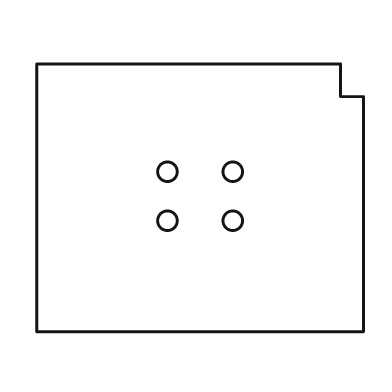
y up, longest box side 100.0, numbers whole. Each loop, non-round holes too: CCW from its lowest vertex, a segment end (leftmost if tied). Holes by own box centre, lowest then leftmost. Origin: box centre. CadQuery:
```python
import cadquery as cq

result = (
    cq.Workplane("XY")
    .moveTo(-50.0, -41.0)
    .lineTo(50.0, -41.0)
    .lineTo(50.0, 31.0)
    .lineTo(43.0, 31.0)
    .lineTo(43.0, 41.0)
    .lineTo(-50.0, 41.0)
    .close()
    .moveTo(-10.0, -7.0)
    .circle(3.0)
    .moveTo(10.0, -7.0)
    .circle(3.0)
    .moveTo(-10.0, 8.0)
    .circle(3.0)
    .moveTo(10.0, 8.0)
    .circle(3.0)
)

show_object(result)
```